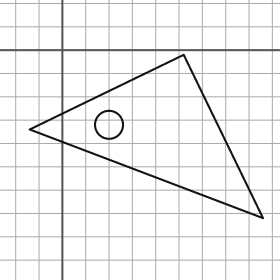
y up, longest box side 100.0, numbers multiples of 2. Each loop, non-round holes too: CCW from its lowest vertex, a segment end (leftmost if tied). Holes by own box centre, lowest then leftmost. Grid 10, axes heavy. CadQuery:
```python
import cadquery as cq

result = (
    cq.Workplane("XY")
    .moveTo(86.0, -72.0)
    .lineTo(52.0, -2.0)
    .lineTo(-14.0, -34.0)
    .close()
    .moveTo(20.0, -32.0)
    .circle(6.0)
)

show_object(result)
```